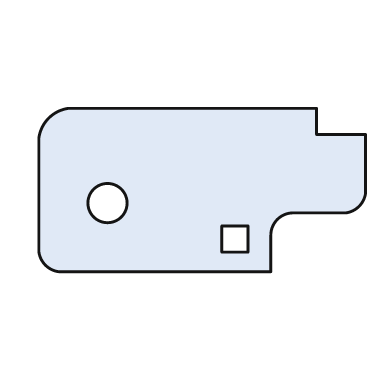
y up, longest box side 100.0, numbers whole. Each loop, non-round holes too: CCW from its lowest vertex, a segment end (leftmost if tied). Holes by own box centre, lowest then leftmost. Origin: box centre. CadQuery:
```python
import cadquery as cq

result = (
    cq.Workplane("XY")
    .moveTo(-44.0, -25.0)
    .lineTo(21.0, -25.0)
    .lineTo(21.0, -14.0)
    .threePointArc((23.0, -9.0), (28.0, -7.0))
    .lineTo(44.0, -7.0)
    .threePointArc((48.0, -5.0), (50.0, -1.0))
    .lineTo(50.0, 17.0)
    .lineTo(35.0, 17.0)
    .lineTo(35.0, 25.0)
    .lineTo(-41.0, 25.0)
    .threePointArc((-47.0, 22.0), (-50.0, 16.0))
    .lineTo(-50.0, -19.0)
    .threePointArc((-48.0, -23.0), (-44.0, -25.0))
    .close()
    .moveTo(6.0, -19.0)
    .lineTo(14.0, -19.0)
    .lineTo(14.0, -11.0)
    .lineTo(6.0, -11.0)
    .close()
    .moveTo(-29.0, -4.0)
    .circle(6.0)
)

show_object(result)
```